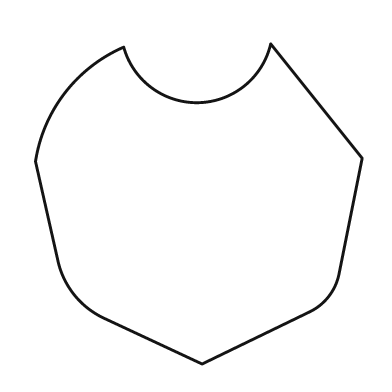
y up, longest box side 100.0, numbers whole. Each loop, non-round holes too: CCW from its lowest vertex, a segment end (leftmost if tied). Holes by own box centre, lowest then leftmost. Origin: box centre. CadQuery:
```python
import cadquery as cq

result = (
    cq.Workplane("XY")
    .moveTo(1.0, -49.0)
    .lineTo(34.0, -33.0)
    .threePointArc((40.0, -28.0), (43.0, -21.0))
    .lineTo(50.0, 14.0)
    .lineTo(22.0, 49.0)
    .threePointArc((0.0, 31.0), (-23.0, 48.0))
    .threePointArc((-41.0, 34.0), (-50.0, 13.0))
    .lineTo(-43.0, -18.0)
    .threePointArc((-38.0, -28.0), (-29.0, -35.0))
    .close()
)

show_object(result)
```